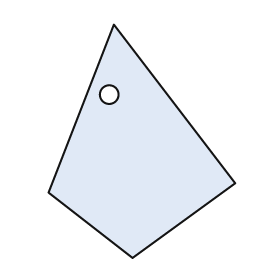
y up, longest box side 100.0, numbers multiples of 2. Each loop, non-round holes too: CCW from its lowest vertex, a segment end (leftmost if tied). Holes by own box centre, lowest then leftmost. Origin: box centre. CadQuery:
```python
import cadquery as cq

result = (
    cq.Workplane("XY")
    .moveTo(-4.0, -50.0)
    .lineTo(40.0, -18.0)
    .lineTo(-12.0, 50.0)
    .lineTo(-40.0, -22.0)
    .close()
    .moveTo(-14.0, 20.0)
    .circle(4.0)
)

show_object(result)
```